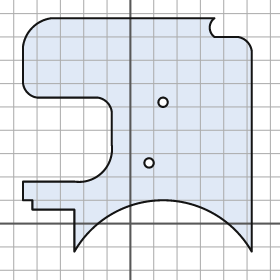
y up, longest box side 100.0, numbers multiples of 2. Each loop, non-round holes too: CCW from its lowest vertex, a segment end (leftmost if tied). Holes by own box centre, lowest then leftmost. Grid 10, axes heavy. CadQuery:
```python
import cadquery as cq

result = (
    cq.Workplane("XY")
    .moveTo(-24.0, -12.0)
    .threePointArc((14.0, 10.0), (52.0, -12.0))
    .lineTo(52.0, 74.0)
    .threePointArc((50.0, 78.0), (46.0, 80.0))
    .lineTo(36.0, 80.0)
    .threePointArc((34.0, 84.0), (36.0, 88.0))
    .lineTo(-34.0, 88.0)
    .threePointArc((-42.0, 84.0), (-46.0, 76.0))
    .lineTo(-46.0, 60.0)
    .threePointArc((-44.0, 56.0), (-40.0, 54.0))
    .lineTo(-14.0, 54.0)
    .threePointArc((-10.0, 52.0), (-8.0, 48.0))
    .lineTo(-8.0, 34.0)
    .threePointArc((-12.0, 22.0), (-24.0, 18.0))
    .lineTo(-46.0, 18.0)
    .lineTo(-46.0, 10.0)
    .lineTo(-42.0, 10.0)
    .lineTo(-42.0, 6.0)
    .lineTo(-24.0, 6.0)
    .close()
    .moveTo(8.0, 26.0)
    .circle(2.0)
    .moveTo(14.0, 52.0)
    .circle(2.0)
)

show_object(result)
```